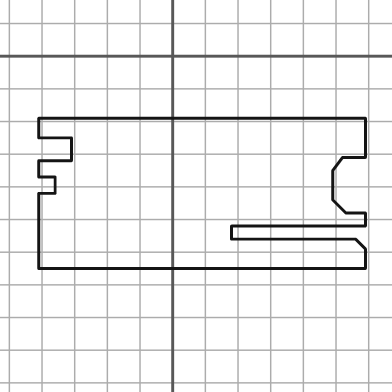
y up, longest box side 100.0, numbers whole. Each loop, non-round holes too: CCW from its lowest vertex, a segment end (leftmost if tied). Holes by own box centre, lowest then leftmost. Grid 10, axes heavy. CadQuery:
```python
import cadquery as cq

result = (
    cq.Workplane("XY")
    .moveTo(-41.0, -65.0)
    .lineTo(59.0, -65.0)
    .lineTo(59.0, -59.0)
    .lineTo(56.0, -56.0)
    .lineTo(18.0, -56.0)
    .lineTo(18.0, -52.0)
    .lineTo(59.0, -52.0)
    .lineTo(59.0, -48.0)
    .lineTo(53.0, -48.0)
    .lineTo(49.0, -44.0)
    .lineTo(49.0, -35.0)
    .lineTo(52.0, -31.0)
    .lineTo(59.0, -31.0)
    .lineTo(59.0, -19.0)
    .lineTo(-41.0, -19.0)
    .lineTo(-41.0, -25.0)
    .lineTo(-31.0, -25.0)
    .lineTo(-31.0, -32.0)
    .lineTo(-41.0, -32.0)
    .lineTo(-41.0, -37.0)
    .lineTo(-36.0, -37.0)
    .lineTo(-36.0, -42.0)
    .lineTo(-41.0, -42.0)
    .close()
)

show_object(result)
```